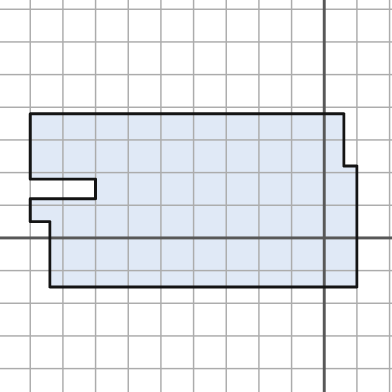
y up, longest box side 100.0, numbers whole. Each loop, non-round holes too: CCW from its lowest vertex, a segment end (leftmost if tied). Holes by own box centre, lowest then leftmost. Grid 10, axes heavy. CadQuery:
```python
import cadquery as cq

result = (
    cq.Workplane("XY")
    .moveTo(-84.0, -15.0)
    .lineTo(10.0, -15.0)
    .lineTo(10.0, 22.0)
    .lineTo(6.0, 22.0)
    .lineTo(6.0, 38.0)
    .lineTo(-90.0, 38.0)
    .lineTo(-90.0, 18.0)
    .lineTo(-70.0, 18.0)
    .lineTo(-70.0, 12.0)
    .lineTo(-90.0, 12.0)
    .lineTo(-90.0, 5.0)
    .lineTo(-84.0, 5.0)
    .close()
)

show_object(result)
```